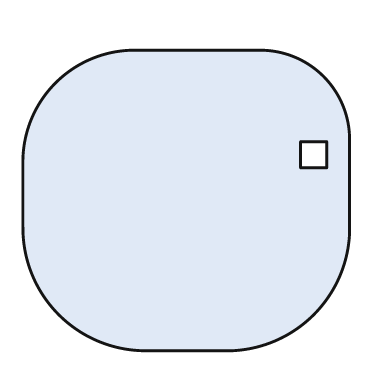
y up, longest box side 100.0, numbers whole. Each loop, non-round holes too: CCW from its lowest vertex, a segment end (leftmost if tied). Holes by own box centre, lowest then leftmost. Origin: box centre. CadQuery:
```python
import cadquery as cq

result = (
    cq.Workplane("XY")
    .moveTo(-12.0, -46.0)
    .lineTo(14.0, -46.0)
    .threePointArc((39.0, -35.0), (50.0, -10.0))
    .lineTo(50.0, 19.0)
    .threePointArc((42.0, 38.0), (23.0, 46.0))
    .lineTo(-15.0, 46.0)
    .threePointArc((-40.0, 36.0), (-50.0, 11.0))
    .lineTo(-50.0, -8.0)
    .threePointArc((-39.0, -35.0), (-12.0, -46.0))
    .close()
    .moveTo(35.0, 10.0)
    .lineTo(43.0, 10.0)
    .lineTo(43.0, 18.0)
    .lineTo(35.0, 18.0)
    .close()
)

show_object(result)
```